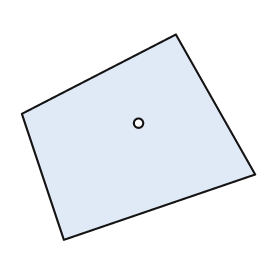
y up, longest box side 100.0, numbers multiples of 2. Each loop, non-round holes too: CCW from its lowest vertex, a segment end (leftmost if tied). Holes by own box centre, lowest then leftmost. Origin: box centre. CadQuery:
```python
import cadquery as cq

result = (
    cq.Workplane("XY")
    .moveTo(-32.0, -44.0)
    .lineTo(50.0, -16.0)
    .lineTo(16.0, 44.0)
    .lineTo(-50.0, 10.0)
    .close()
    .moveTo(0.0, 6.0)
    .circle(2.0)
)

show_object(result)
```